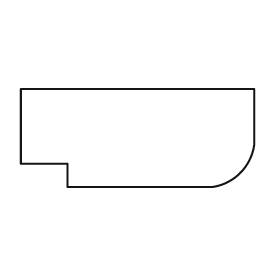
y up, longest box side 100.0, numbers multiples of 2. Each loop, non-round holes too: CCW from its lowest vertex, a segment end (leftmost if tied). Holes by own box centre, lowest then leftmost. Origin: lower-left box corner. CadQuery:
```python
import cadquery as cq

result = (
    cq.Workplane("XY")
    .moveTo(20.0, 0.0)
    .lineTo(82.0, 0.0)
    .threePointArc((94.0, 6.0), (100.0, 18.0))
    .lineTo(100.0, 42.0)
    .lineTo(0.0, 42.0)
    .lineTo(0.0, 10.0)
    .lineTo(20.0, 10.0)
    .close()
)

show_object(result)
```